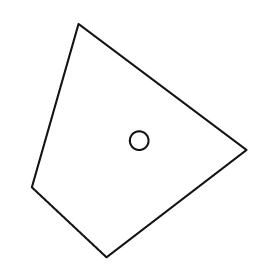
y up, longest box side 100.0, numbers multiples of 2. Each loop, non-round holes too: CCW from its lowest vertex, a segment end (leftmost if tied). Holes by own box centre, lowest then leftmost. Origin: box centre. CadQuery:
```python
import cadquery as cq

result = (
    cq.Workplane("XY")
    .moveTo(-14.0, -50.0)
    .lineTo(46.0, -4.0)
    .lineTo(-26.0, 50.0)
    .lineTo(-46.0, -20.0)
    .close()
    .moveTo(0.0, 0.0)
    .circle(4.0)
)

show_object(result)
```